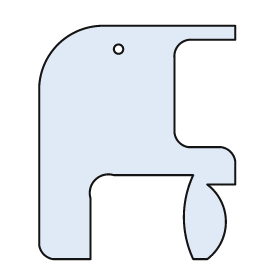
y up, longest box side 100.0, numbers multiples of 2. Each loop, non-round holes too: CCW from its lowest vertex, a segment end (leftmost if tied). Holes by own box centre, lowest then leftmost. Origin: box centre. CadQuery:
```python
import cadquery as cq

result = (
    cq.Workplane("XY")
    .moveTo(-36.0, -50.0)
    .lineTo(-20.0, -50.0)
    .lineTo(-20.0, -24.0)
    .threePointArc((-18.0, -16.0), (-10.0, -14.0))
    .lineTo(24.0, -14.0)
    .threePointArc((20.0, -32.0), (24.0, -50.0))
    .lineTo(30.0, -50.0)
    .threePointArc((38.0, -34.0), (30.0, -18.0))
    .lineTo(42.0, -18.0)
    .lineTo(42.0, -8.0)
    .threePointArc((40.0, -4.0), (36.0, -2.0))
    .lineTo(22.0, -2.0)
    .threePointArc((18.0, 0.0), (16.0, 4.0))
    .lineTo(16.0, 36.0)
    .threePointArc((18.0, 42.0), (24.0, 44.0))
    .lineTo(42.0, 44.0)
    .lineTo(42.0, 50.0)
    .lineTo(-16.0, 50.0)
    .threePointArc((-34.0, 42.0), (-42.0, 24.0))
    .lineTo(-42.0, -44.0)
    .threePointArc((-40.0, -48.0), (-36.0, -50.0))
    .close()
    .moveTo(-8.0, 40.0)
    .circle(2.0)
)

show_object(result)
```